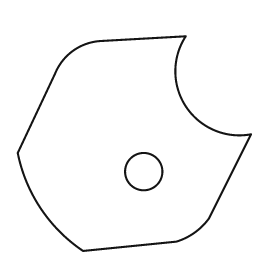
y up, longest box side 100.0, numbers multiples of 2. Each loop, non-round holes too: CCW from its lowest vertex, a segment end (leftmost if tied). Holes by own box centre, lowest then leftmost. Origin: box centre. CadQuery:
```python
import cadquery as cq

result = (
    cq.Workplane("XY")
    .moveTo(-22.0, -46.0)
    .lineTo(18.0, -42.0)
    .threePointArc((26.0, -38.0), (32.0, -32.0))
    .lineTo(50.0, 4.0)
    .threePointArc((22.0, 16.0), (22.0, 46.0))
    .lineTo(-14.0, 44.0)
    .threePointArc((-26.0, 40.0), (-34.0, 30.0))
    .lineTo(-50.0, -4.0)
    .threePointArc((-40.0, -28.0), (-22.0, -46.0))
    .close()
    .moveTo(4.0, -12.0)
    .circle(8.0)
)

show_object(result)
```